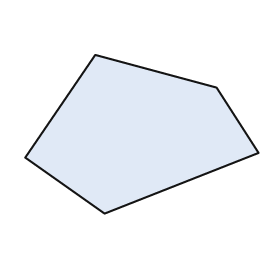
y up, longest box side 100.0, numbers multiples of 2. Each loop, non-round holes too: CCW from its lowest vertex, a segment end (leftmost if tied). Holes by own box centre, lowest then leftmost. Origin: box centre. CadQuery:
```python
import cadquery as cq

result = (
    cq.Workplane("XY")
    .moveTo(-16.0, -34.0)
    .lineTo(50.0, -8.0)
    .lineTo(32.0, 20.0)
    .lineTo(-20.0, 34.0)
    .lineTo(-50.0, -10.0)
    .close()
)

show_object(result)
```